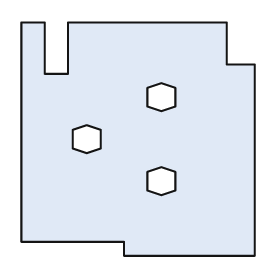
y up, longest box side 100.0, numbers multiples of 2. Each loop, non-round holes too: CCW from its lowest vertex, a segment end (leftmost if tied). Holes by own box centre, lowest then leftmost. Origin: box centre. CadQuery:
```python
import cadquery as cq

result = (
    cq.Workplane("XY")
    .moveTo(-6.0, -50.0)
    .lineTo(50.0, -50.0)
    .lineTo(50.0, 32.0)
    .lineTo(38.0, 32.0)
    .lineTo(38.0, 50.0)
    .lineTo(-30.0, 50.0)
    .lineTo(-30.0, 28.0)
    .lineTo(-40.0, 28.0)
    .lineTo(-40.0, 50.0)
    .lineTo(-50.0, 50.0)
    .lineTo(-50.0, -44.0)
    .lineTo(-6.0, -44.0)
    .close()
    .moveTo(10.0, -24.0)
    .lineTo(16.0, -22.0)
    .lineTo(16.0, -14.0)
    .lineTo(10.0, -12.0)
    .lineTo(4.0, -14.0)
    .lineTo(4.0, -22.0)
    .close()
    .moveTo(-22.0, -6.0)
    .lineTo(-16.0, -4.0)
    .lineTo(-16.0, 4.0)
    .lineTo(-22.0, 6.0)
    .lineTo(-28.0, 4.0)
    .lineTo(-28.0, -4.0)
    .close()
    .moveTo(10.0, 12.0)
    .lineTo(16.0, 14.0)
    .lineTo(16.0, 22.0)
    .lineTo(10.0, 24.0)
    .lineTo(4.0, 22.0)
    .lineTo(4.0, 14.0)
    .close()
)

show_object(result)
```